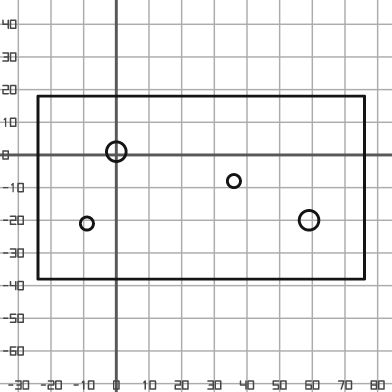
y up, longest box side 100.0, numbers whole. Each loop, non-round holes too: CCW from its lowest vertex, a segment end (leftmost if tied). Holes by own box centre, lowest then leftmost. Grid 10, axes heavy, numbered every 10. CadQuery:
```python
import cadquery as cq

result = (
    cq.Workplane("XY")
    .moveTo(-24.0, -38.0)
    .lineTo(76.0, -38.0)
    .lineTo(76.0, 18.0)
    .lineTo(-24.0, 18.0)
    .close()
    .moveTo(-9.0, -21.0)
    .circle(2.0)
    .moveTo(59.0, -20.0)
    .circle(3.0)
    .moveTo(36.0, -8.0)
    .circle(2.0)
    .moveTo(0.0, 1.0)
    .circle(3.0)
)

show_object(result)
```